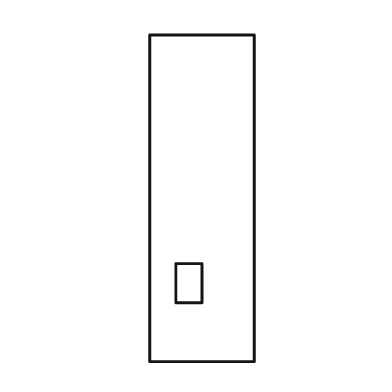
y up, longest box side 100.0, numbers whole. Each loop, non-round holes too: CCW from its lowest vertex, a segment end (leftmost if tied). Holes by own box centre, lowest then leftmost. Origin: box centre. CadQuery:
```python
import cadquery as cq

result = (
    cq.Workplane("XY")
    .moveTo(-16.0, -50.0)
    .lineTo(16.0, -50.0)
    .lineTo(16.0, 50.0)
    .lineTo(-16.0, 50.0)
    .close()
    .moveTo(-8.0, -32.0)
    .lineTo(0.0, -32.0)
    .lineTo(0.0, -20.0)
    .lineTo(-8.0, -20.0)
    .close()
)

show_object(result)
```